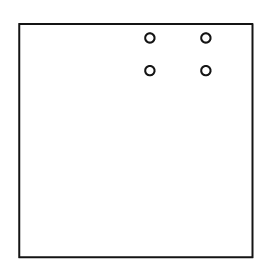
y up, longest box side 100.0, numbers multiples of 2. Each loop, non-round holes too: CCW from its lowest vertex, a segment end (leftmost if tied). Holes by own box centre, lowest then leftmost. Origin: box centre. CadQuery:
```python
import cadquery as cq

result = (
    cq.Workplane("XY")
    .moveTo(-50.0, -50.0)
    .lineTo(50.0, -50.0)
    .lineTo(50.0, 50.0)
    .lineTo(-50.0, 50.0)
    .close()
    .moveTo(6.0, 30.0)
    .circle(2.0)
    .moveTo(30.0, 30.0)
    .circle(2.0)
    .moveTo(6.0, 44.0)
    .circle(2.0)
    .moveTo(30.0, 44.0)
    .circle(2.0)
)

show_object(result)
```